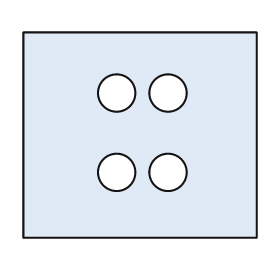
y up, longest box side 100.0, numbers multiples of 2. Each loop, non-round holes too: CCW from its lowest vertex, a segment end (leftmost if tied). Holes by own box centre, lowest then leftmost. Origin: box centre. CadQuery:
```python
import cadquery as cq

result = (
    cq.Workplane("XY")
    .moveTo(-50.0, -44.0)
    .lineTo(50.0, -44.0)
    .lineTo(50.0, 44.0)
    .lineTo(-50.0, 44.0)
    .close()
    .moveTo(-10.0, -16.0)
    .circle(8.0)
    .moveTo(12.0, -16.0)
    .circle(8.0)
    .moveTo(-10.0, 18.0)
    .circle(8.0)
    .moveTo(12.0, 18.0)
    .circle(8.0)
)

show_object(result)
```